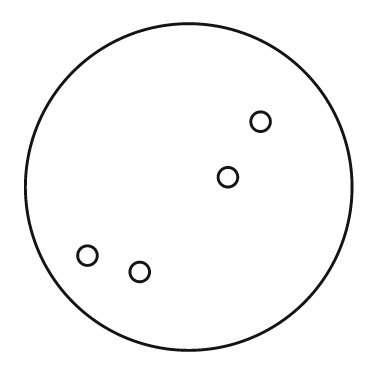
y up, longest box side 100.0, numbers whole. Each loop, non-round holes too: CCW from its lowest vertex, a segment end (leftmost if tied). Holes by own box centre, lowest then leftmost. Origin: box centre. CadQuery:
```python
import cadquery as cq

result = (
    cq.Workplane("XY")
    .moveTo(0.0, 0.0)
    .circle(50.0)
    .moveTo(-15.0, -26.0)
    .circle(3.0)
    .moveTo(-31.0, -21.0)
    .circle(3.0)
    .moveTo(12.0, 3.0)
    .circle(3.0)
    .moveTo(22.0, 20.0)
    .circle(3.0)
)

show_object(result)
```